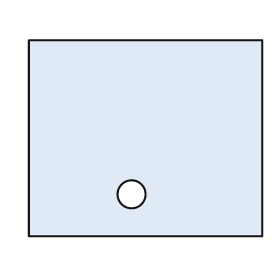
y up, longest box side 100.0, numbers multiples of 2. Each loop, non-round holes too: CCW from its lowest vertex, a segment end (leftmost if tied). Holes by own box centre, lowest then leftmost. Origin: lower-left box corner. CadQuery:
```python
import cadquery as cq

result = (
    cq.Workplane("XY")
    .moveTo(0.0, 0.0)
    .lineTo(100.0, 0.0)
    .lineTo(100.0, 84.0)
    .lineTo(0.0, 84.0)
    .close()
    .moveTo(44.0, 18.0)
    .circle(6.0)
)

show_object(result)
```